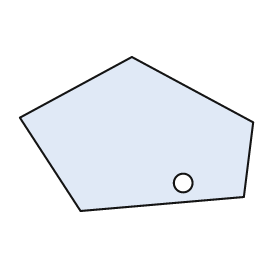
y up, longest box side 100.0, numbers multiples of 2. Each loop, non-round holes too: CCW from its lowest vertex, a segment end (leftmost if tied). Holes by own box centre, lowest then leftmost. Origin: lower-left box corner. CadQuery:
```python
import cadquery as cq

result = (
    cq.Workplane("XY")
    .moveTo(26.0, 0.0)
    .lineTo(96.0, 6.0)
    .lineTo(100.0, 38.0)
    .lineTo(48.0, 66.0)
    .lineTo(0.0, 40.0)
    .close()
    .moveTo(70.0, 12.0)
    .circle(4.0)
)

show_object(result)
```